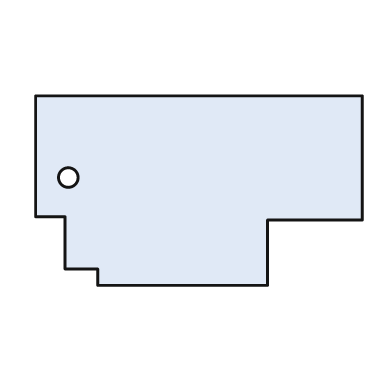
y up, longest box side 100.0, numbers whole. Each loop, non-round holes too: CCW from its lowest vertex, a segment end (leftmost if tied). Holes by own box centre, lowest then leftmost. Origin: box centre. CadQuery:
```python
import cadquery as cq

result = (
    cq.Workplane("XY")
    .moveTo(-31.0, -29.0)
    .lineTo(21.0, -29.0)
    .lineTo(21.0, -9.0)
    .lineTo(50.0, -9.0)
    .lineTo(50.0, 29.0)
    .lineTo(-50.0, 29.0)
    .lineTo(-50.0, -8.0)
    .lineTo(-41.0, -8.0)
    .lineTo(-41.0, -24.0)
    .lineTo(-31.0, -24.0)
    .close()
    .moveTo(-40.0, 4.0)
    .circle(3.0)
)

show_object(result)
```